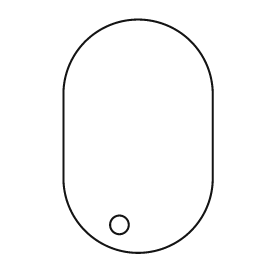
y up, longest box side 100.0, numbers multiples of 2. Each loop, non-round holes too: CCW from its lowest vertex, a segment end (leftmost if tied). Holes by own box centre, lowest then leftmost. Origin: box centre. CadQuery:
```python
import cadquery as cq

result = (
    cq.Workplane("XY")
    .moveTo(-32.0, -18.0)
    .threePointArc((0.0, -50.0), (32.0, -18.0))
    .lineTo(32.0, 18.0)
    .threePointArc((0.0, 50.0), (-32.0, 18.0))
    .close()
    .moveTo(-8.0, -38.0)
    .circle(4.0)
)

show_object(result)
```